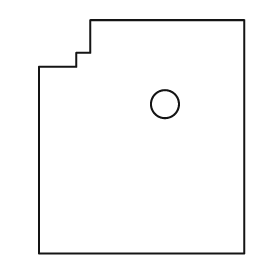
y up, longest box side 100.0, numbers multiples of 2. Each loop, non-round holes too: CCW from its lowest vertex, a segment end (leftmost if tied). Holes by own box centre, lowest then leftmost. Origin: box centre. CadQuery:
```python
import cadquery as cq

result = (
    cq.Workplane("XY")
    .moveTo(-44.0, -50.0)
    .lineTo(44.0, -50.0)
    .lineTo(44.0, 50.0)
    .lineTo(-22.0, 50.0)
    .lineTo(-22.0, 36.0)
    .lineTo(-28.0, 36.0)
    .lineTo(-28.0, 30.0)
    .lineTo(-44.0, 30.0)
    .close()
    .moveTo(10.0, 14.0)
    .circle(6.0)
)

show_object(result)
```